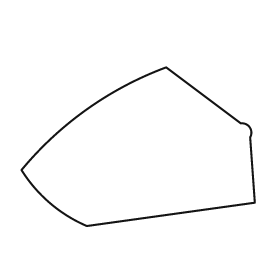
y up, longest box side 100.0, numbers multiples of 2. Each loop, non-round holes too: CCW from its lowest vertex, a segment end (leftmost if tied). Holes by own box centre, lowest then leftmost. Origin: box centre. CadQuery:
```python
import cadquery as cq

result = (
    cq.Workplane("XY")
    .moveTo(-22.0, -34.0)
    .lineTo(50.0, -24.0)
    .lineTo(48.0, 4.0)
    .threePointArc((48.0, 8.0), (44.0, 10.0))
    .lineTo(12.0, 34.0)
    .threePointArc((-22.0, 16.0), (-50.0, -10.0))
    .threePointArc((-38.0, -24.0), (-22.0, -34.0))
    .close()
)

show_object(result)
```